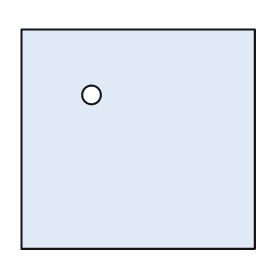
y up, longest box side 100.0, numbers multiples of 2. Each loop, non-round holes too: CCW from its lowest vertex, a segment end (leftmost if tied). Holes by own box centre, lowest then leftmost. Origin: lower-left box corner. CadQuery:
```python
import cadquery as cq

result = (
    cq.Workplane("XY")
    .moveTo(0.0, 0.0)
    .lineTo(100.0, 0.0)
    .lineTo(100.0, 94.0)
    .lineTo(0.0, 94.0)
    .close()
    .moveTo(30.0, 66.0)
    .circle(4.0)
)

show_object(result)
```